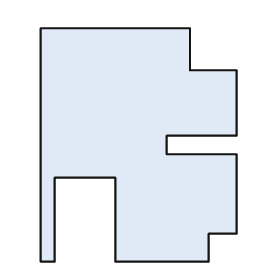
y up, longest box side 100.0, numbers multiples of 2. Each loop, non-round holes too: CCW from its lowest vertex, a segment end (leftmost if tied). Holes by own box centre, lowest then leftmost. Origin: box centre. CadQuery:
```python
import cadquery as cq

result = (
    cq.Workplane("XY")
    .moveTo(-42.0, -50.0)
    .lineTo(-36.0, -50.0)
    .lineTo(-36.0, -14.0)
    .lineTo(-10.0, -14.0)
    .lineTo(-10.0, -50.0)
    .lineTo(30.0, -50.0)
    .lineTo(30.0, -38.0)
    .lineTo(42.0, -38.0)
    .lineTo(42.0, -4.0)
    .lineTo(12.0, -4.0)
    .lineTo(12.0, 4.0)
    .lineTo(42.0, 4.0)
    .lineTo(42.0, 32.0)
    .lineTo(22.0, 32.0)
    .lineTo(22.0, 50.0)
    .lineTo(-42.0, 50.0)
    .close()
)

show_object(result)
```